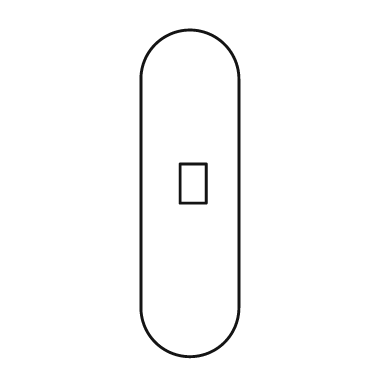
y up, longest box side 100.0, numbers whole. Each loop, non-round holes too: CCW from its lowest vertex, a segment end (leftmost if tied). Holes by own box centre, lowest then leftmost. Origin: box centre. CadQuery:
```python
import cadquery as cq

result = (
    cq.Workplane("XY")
    .moveTo(-15.0, -35.0)
    .threePointArc((0.0, -50.0), (15.0, -35.0))
    .lineTo(15.0, 35.0)
    .threePointArc((0.0, 50.0), (-15.0, 35.0))
    .close()
    .moveTo(-3.0, -3.0)
    .lineTo(5.0, -3.0)
    .lineTo(5.0, 9.0)
    .lineTo(-3.0, 9.0)
    .close()
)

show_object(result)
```